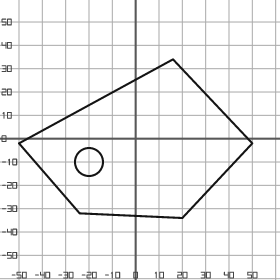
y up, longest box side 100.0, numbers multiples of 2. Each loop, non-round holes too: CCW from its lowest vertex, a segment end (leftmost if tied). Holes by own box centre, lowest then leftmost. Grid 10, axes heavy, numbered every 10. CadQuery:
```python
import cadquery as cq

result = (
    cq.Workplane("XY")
    .moveTo(20.0, -34.0)
    .lineTo(50.0, -2.0)
    .lineTo(16.0, 34.0)
    .lineTo(-50.0, -2.0)
    .lineTo(-24.0, -32.0)
    .close()
    .moveTo(-20.0, -10.0)
    .circle(6.0)
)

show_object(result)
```